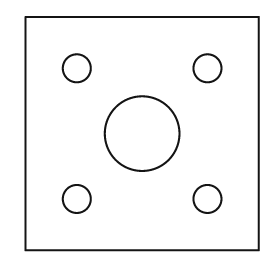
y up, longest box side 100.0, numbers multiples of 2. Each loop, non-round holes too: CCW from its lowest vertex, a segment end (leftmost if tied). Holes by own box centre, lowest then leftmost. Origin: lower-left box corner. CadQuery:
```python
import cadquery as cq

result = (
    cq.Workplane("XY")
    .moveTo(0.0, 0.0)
    .lineTo(100.0, 0.0)
    .lineTo(100.0, 100.0)
    .lineTo(0.0, 100.0)
    .close()
    .moveTo(22.0, 22.0)
    .circle(6.0)
    .moveTo(78.0, 22.0)
    .circle(6.0)
    .moveTo(50.0, 50.0)
    .circle(16.0)
    .moveTo(22.0, 78.0)
    .circle(6.0)
    .moveTo(78.0, 78.0)
    .circle(6.0)
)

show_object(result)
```